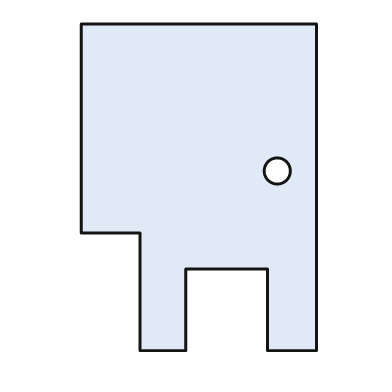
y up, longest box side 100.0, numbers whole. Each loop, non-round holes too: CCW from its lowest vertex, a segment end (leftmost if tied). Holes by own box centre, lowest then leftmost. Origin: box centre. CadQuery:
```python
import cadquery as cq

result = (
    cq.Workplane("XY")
    .moveTo(-18.0, -50.0)
    .lineTo(-4.0, -50.0)
    .lineTo(-4.0, -25.0)
    .lineTo(21.0, -25.0)
    .lineTo(21.0, -50.0)
    .lineTo(36.0, -50.0)
    .lineTo(36.0, 50.0)
    .lineTo(-36.0, 50.0)
    .lineTo(-36.0, -14.0)
    .lineTo(-18.0, -14.0)
    .close()
    .moveTo(24.0, 5.0)
    .circle(4.0)
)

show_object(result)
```